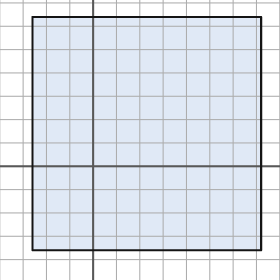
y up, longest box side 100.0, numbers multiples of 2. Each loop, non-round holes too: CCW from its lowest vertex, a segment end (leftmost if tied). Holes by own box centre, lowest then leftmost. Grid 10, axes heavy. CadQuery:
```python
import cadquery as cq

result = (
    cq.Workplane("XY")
    .moveTo(-26.0, -36.0)
    .lineTo(72.0, -36.0)
    .lineTo(72.0, 64.0)
    .lineTo(-26.0, 64.0)
    .close()
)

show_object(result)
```